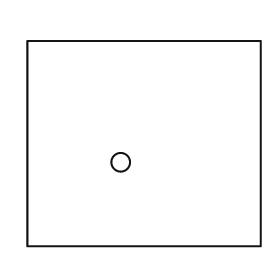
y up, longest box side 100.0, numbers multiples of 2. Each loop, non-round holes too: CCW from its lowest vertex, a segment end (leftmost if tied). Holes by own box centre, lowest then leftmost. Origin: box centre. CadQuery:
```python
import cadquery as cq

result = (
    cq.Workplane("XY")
    .moveTo(-50.0, -44.0)
    .lineTo(50.0, -44.0)
    .lineTo(50.0, 44.0)
    .lineTo(-50.0, 44.0)
    .close()
    .moveTo(-10.0, -8.0)
    .circle(4.0)
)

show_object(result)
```